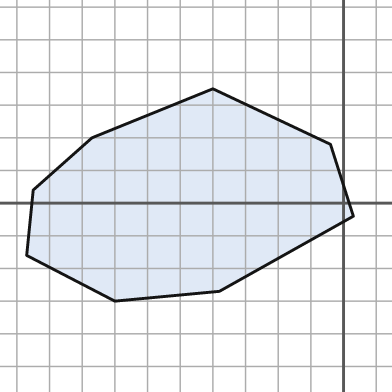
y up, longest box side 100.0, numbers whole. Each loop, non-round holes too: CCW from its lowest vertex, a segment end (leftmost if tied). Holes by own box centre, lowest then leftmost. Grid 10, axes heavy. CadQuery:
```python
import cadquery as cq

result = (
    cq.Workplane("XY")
    .moveTo(-70.0, -30.0)
    .lineTo(-38.0, -27.0)
    .lineTo(3.0, -4.0)
    .lineTo(-4.0, 18.0)
    .lineTo(-40.0, 35.0)
    .lineTo(-77.0, 20.0)
    .lineTo(-95.0, 4.0)
    .lineTo(-97.0, -16.0)
    .close()
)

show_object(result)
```